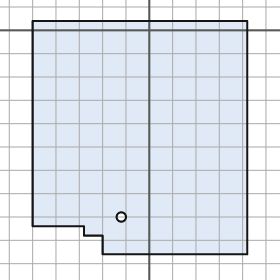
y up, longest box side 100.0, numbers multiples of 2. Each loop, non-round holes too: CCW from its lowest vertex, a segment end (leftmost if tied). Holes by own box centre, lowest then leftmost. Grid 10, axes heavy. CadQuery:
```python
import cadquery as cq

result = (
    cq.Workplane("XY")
    .moveTo(-20.0, -96.0)
    .lineTo(42.0, -96.0)
    .lineTo(42.0, 4.0)
    .lineTo(-50.0, 4.0)
    .lineTo(-50.0, -84.0)
    .lineTo(-28.0, -84.0)
    .lineTo(-28.0, -88.0)
    .lineTo(-20.0, -88.0)
    .close()
    .moveTo(-12.0, -80.0)
    .circle(2.0)
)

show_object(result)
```